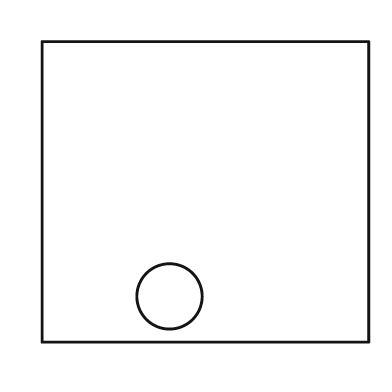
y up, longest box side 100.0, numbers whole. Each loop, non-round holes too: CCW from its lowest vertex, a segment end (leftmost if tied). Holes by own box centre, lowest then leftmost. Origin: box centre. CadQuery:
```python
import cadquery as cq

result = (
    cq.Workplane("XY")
    .moveTo(-50.0, -46.0)
    .lineTo(50.0, -46.0)
    .lineTo(50.0, 46.0)
    .lineTo(-50.0, 46.0)
    .close()
    .moveTo(-11.0, -32.0)
    .circle(10.0)
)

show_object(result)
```